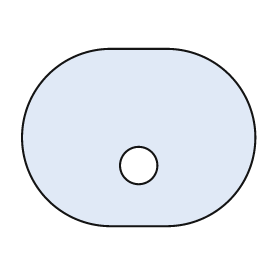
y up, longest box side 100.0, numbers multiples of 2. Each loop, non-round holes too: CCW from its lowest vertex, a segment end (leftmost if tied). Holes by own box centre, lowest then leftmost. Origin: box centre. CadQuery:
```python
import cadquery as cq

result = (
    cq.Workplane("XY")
    .moveTo(-12.0, -38.0)
    .lineTo(12.0, -38.0)
    .threePointArc((50.0, 0.0), (12.0, 38.0))
    .lineTo(-12.0, 38.0)
    .threePointArc((-50.0, 0.0), (-12.0, -38.0))
    .close()
    .moveTo(0.0, -12.0)
    .circle(8.0)
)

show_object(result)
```